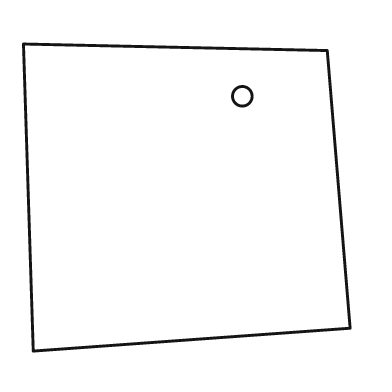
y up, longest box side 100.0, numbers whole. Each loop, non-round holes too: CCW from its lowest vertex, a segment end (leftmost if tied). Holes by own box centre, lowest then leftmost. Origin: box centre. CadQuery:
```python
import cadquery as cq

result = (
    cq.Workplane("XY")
    .moveTo(-47.0, -47.0)
    .lineTo(50.0, -40.0)
    .lineTo(43.0, 45.0)
    .lineTo(-50.0, 47.0)
    .close()
    .moveTo(17.0, 31.0)
    .circle(3.0)
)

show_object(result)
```